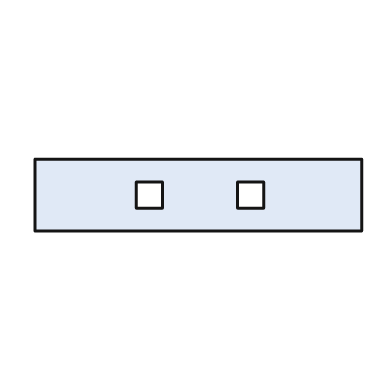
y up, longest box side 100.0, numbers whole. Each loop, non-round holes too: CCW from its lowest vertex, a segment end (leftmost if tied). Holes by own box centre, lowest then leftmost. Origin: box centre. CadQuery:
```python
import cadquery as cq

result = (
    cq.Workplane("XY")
    .moveTo(-50.0, -11.0)
    .lineTo(50.0, -11.0)
    .lineTo(50.0, 11.0)
    .lineTo(-50.0, 11.0)
    .close()
    .moveTo(-19.0, -4.0)
    .lineTo(-11.0, -4.0)
    .lineTo(-11.0, 4.0)
    .lineTo(-19.0, 4.0)
    .close()
    .moveTo(12.0, -4.0)
    .lineTo(20.0, -4.0)
    .lineTo(20.0, 4.0)
    .lineTo(12.0, 4.0)
    .close()
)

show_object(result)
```